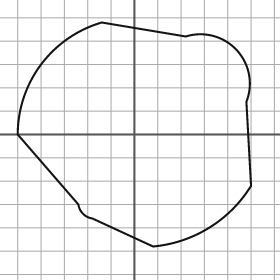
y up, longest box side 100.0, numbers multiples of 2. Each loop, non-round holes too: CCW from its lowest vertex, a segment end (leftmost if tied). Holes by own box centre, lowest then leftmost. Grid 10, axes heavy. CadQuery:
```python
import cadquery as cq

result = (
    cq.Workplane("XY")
    .moveTo(8.0, -48.0)
    .threePointArc((32.0, -40.0), (50.0, -22.0))
    .lineTo(48.0, 14.0)
    .threePointArc((44.0, 36.0), (22.0, 42.0))
    .lineTo(-14.0, 48.0)
    .threePointArc((-40.0, 30.0), (-50.0, 0.0))
    .lineTo(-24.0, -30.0)
    .threePointArc((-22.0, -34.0), (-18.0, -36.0))
    .close()
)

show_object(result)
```